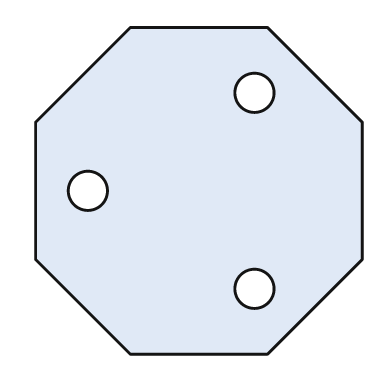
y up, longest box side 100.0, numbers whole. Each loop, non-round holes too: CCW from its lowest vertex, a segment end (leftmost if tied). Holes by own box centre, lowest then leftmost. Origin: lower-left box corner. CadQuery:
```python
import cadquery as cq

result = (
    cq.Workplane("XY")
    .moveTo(29.0, 0.0)
    .lineTo(71.0, 0.0)
    .lineTo(100.0, 29.0)
    .lineTo(100.0, 71.0)
    .lineTo(71.0, 100.0)
    .lineTo(29.0, 100.0)
    .lineTo(0.0, 71.0)
    .lineTo(0.0, 29.0)
    .close()
    .moveTo(67.0, 20.0)
    .circle(6.0)
    .moveTo(16.0, 50.0)
    .circle(6.0)
    .moveTo(67.0, 80.0)
    .circle(6.0)
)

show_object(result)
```